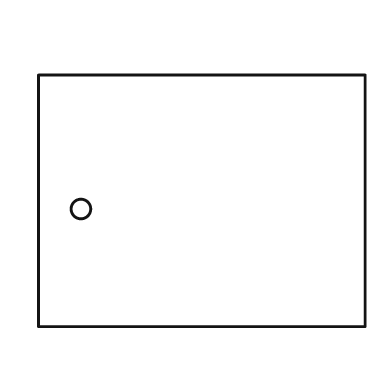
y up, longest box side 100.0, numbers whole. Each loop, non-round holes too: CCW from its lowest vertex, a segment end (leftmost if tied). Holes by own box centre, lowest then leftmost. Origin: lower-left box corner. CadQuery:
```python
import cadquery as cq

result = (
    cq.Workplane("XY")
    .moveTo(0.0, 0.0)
    .lineTo(100.0, 0.0)
    .lineTo(100.0, 77.0)
    .lineTo(0.0, 77.0)
    .close()
    .moveTo(13.0, 36.0)
    .circle(3.0)
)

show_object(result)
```